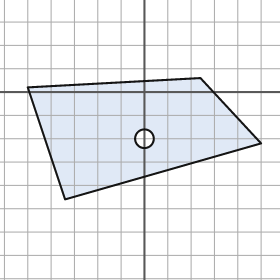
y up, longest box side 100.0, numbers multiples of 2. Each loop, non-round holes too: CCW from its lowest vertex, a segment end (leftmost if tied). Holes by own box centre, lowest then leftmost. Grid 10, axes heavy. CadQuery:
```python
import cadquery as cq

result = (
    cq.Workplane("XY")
    .moveTo(-34.0, -46.0)
    .lineTo(50.0, -22.0)
    .lineTo(24.0, 6.0)
    .lineTo(-50.0, 2.0)
    .close()
    .moveTo(0.0, -20.0)
    .circle(4.0)
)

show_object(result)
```